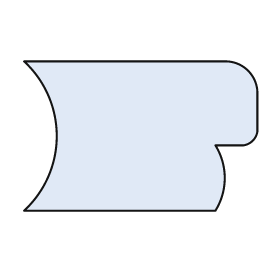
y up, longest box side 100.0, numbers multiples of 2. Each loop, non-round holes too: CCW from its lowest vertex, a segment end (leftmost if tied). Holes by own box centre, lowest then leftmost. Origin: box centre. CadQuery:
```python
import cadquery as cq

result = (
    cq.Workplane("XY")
    .moveTo(-50.0, -32.0)
    .lineTo(32.0, -32.0)
    .threePointArc((36.0, -18.0), (32.0, -4.0))
    .lineTo(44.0, -4.0)
    .threePointArc((48.0, -2.0), (50.0, 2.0))
    .lineTo(50.0, 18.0)
    .threePointArc((46.0, 28.0), (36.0, 32.0))
    .lineTo(-50.0, 32.0)
    .threePointArc((-36.0, 0.0), (-50.0, -32.0))
    .close()
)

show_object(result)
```